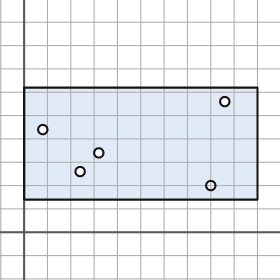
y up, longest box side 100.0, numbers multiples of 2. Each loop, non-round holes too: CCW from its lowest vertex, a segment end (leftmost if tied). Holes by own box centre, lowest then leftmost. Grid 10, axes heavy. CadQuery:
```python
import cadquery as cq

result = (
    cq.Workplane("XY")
    .moveTo(0.0, 14.0)
    .lineTo(100.0, 14.0)
    .lineTo(100.0, 62.0)
    .lineTo(0.0, 62.0)
    .close()
    .moveTo(80.0, 20.0)
    .circle(2.0)
    .moveTo(24.0, 26.0)
    .circle(2.0)
    .moveTo(32.0, 34.0)
    .circle(2.0)
    .moveTo(8.0, 44.0)
    .circle(2.0)
    .moveTo(86.0, 56.0)
    .circle(2.0)
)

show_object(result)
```